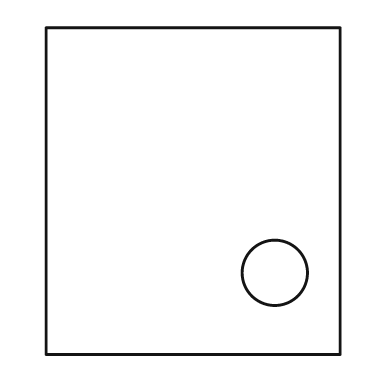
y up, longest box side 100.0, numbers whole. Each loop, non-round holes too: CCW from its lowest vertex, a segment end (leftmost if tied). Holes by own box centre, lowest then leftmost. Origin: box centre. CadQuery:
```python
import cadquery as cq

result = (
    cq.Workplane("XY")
    .moveTo(-45.0, -50.0)
    .lineTo(45.0, -50.0)
    .lineTo(45.0, 50.0)
    .lineTo(-45.0, 50.0)
    .close()
    .moveTo(25.0, -25.0)
    .circle(10.0)
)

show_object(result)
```